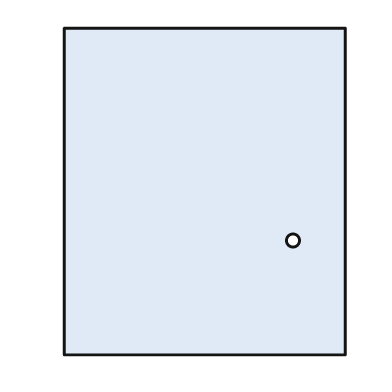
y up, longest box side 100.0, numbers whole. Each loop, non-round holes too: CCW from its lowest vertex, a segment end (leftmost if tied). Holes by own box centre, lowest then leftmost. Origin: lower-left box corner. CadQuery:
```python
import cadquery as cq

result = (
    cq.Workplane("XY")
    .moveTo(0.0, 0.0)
    .lineTo(86.0, 0.0)
    .lineTo(86.0, 100.0)
    .lineTo(0.0, 100.0)
    .close()
    .moveTo(70.0, 35.0)
    .circle(2.0)
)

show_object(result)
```